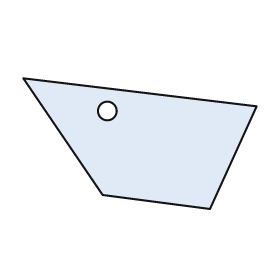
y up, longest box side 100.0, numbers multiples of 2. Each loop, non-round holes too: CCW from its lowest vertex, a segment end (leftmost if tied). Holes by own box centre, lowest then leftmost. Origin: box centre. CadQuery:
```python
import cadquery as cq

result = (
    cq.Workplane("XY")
    .moveTo(30.0, -28.0)
    .lineTo(50.0, 16.0)
    .lineTo(-50.0, 28.0)
    .lineTo(-16.0, -22.0)
    .close()
    .moveTo(-14.0, 14.0)
    .circle(4.0)
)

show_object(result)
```